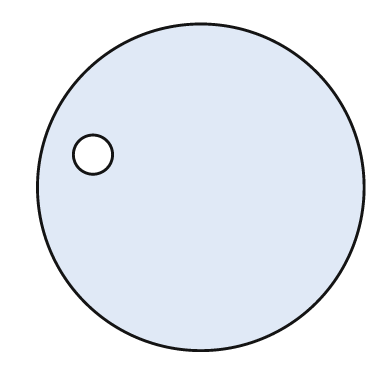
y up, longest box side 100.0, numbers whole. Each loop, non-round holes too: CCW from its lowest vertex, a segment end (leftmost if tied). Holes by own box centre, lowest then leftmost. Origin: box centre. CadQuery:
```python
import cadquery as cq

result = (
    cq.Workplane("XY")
    .moveTo(0.0, 0.0)
    .circle(50.0)
    .moveTo(-33.0, 10.0)
    .circle(6.0)
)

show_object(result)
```